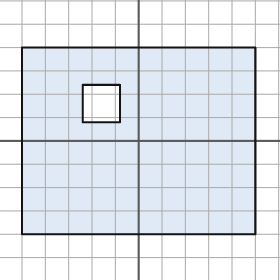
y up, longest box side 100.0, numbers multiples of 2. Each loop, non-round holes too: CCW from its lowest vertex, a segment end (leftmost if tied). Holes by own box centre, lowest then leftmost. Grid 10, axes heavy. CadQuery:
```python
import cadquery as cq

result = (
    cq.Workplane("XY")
    .moveTo(-50.0, -40.0)
    .lineTo(50.0, -40.0)
    .lineTo(50.0, 40.0)
    .lineTo(-50.0, 40.0)
    .close()
    .moveTo(-24.0, 8.0)
    .lineTo(-8.0, 8.0)
    .lineTo(-8.0, 24.0)
    .lineTo(-24.0, 24.0)
    .close()
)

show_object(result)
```